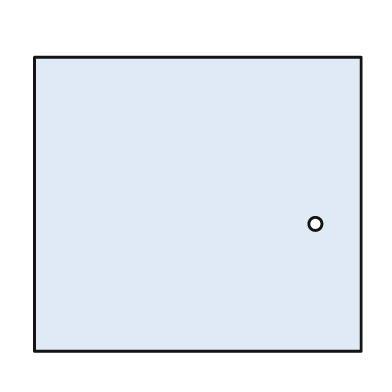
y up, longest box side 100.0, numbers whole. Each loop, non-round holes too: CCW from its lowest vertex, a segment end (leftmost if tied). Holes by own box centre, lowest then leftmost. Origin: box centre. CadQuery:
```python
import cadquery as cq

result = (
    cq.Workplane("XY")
    .moveTo(-50.0, -45.0)
    .lineTo(50.0, -45.0)
    .lineTo(50.0, 45.0)
    .lineTo(-50.0, 45.0)
    .close()
    .moveTo(36.0, -6.0)
    .circle(2.0)
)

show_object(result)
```